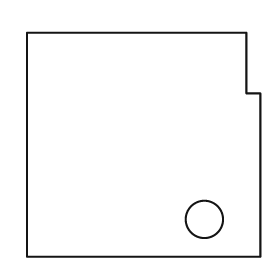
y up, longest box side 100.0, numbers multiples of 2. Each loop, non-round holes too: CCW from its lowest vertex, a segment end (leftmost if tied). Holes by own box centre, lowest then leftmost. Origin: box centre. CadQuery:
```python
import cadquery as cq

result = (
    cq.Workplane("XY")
    .moveTo(-50.0, -48.0)
    .lineTo(50.0, -48.0)
    .lineTo(50.0, 22.0)
    .lineTo(44.0, 22.0)
    .lineTo(44.0, 48.0)
    .lineTo(-50.0, 48.0)
    .close()
    .moveTo(26.0, -32.0)
    .circle(8.0)
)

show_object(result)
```